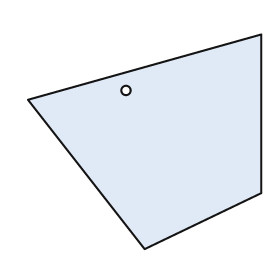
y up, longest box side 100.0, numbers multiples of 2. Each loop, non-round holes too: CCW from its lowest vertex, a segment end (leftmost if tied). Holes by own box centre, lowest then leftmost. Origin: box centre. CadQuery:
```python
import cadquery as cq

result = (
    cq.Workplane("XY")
    .moveTo(0.0, -46.0)
    .lineTo(50.0, -22.0)
    .lineTo(50.0, 46.0)
    .lineTo(-50.0, 18.0)
    .close()
    .moveTo(-8.0, 22.0)
    .circle(2.0)
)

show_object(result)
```